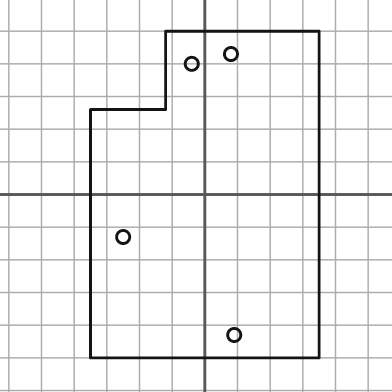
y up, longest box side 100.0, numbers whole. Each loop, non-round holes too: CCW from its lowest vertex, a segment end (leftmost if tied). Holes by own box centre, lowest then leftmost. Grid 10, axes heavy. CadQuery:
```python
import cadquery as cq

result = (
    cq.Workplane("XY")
    .moveTo(-35.0, -50.0)
    .lineTo(35.0, -50.0)
    .lineTo(35.0, 50.0)
    .lineTo(-12.0, 50.0)
    .lineTo(-12.0, 26.0)
    .lineTo(-35.0, 26.0)
    .close()
    .moveTo(9.0, -43.0)
    .circle(2.0)
    .moveTo(-25.0, -13.0)
    .circle(2.0)
    .moveTo(-4.0, 40.0)
    .circle(2.0)
    .moveTo(8.0, 43.0)
    .circle(2.0)
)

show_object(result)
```